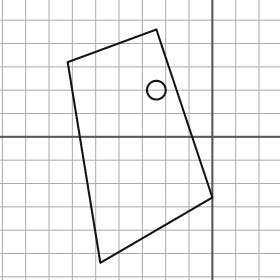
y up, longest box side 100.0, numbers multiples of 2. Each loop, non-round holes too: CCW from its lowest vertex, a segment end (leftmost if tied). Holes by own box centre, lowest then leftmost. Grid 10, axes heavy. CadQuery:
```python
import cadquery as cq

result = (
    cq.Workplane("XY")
    .moveTo(-48.0, -54.0)
    .lineTo(0.0, -26.0)
    .lineTo(-24.0, 46.0)
    .lineTo(-62.0, 32.0)
    .close()
    .moveTo(-24.0, 20.0)
    .circle(4.0)
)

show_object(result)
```